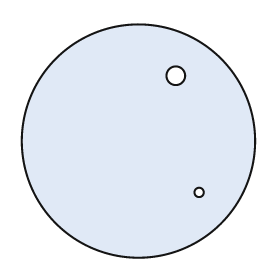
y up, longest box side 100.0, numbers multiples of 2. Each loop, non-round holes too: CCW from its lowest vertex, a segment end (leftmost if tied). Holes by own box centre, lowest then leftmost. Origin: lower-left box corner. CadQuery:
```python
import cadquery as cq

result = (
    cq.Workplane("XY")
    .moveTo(50.0, 50.0)
    .circle(50.0)
    .moveTo(76.0, 28.0)
    .circle(2.0)
    .moveTo(66.0, 78.0)
    .circle(4.0)
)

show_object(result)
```